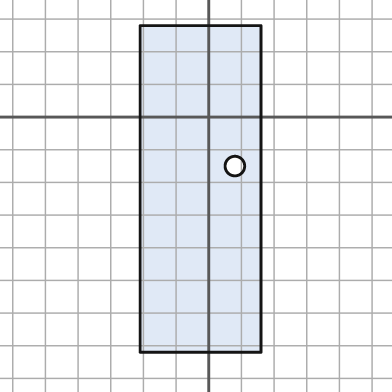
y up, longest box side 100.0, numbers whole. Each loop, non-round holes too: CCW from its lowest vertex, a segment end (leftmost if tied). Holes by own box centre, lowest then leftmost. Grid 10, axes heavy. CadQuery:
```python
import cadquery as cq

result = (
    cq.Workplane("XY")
    .moveTo(-21.0, -72.0)
    .lineTo(16.0, -72.0)
    .lineTo(16.0, 28.0)
    .lineTo(-21.0, 28.0)
    .close()
    .moveTo(8.0, -15.0)
    .circle(3.0)
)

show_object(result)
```